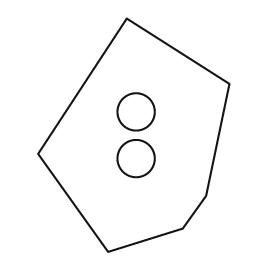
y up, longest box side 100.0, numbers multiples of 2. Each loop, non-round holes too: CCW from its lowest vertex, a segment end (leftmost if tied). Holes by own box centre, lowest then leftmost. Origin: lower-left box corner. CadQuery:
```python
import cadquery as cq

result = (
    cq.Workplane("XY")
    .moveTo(30.0, 0.0)
    .lineTo(62.0, 10.0)
    .lineTo(72.0, 24.0)
    .lineTo(82.0, 72.0)
    .lineTo(38.0, 100.0)
    .lineTo(0.0, 42.0)
    .close()
    .moveTo(42.0, 40.0)
    .circle(8.0)
    .moveTo(42.0, 60.0)
    .circle(8.0)
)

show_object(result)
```